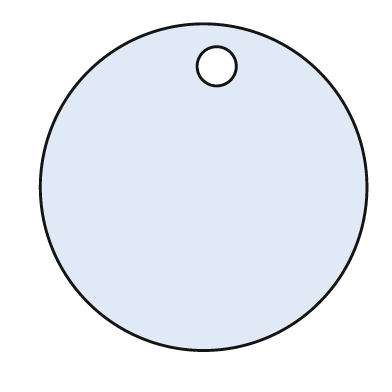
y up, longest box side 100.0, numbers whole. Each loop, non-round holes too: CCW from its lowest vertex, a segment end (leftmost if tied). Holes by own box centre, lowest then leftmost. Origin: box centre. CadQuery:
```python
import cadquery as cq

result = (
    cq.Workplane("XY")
    .moveTo(0.0, 0.0)
    .circle(50.0)
    .moveTo(4.0, 37.0)
    .circle(6.0)
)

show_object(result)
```